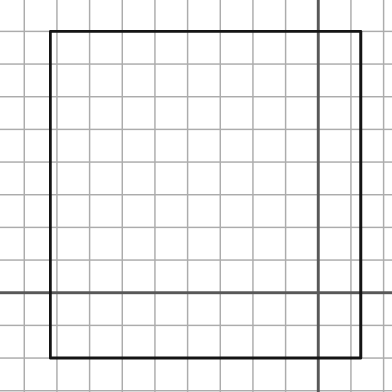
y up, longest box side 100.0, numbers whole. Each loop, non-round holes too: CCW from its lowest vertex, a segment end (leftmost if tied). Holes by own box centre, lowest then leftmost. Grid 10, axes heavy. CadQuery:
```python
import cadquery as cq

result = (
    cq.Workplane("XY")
    .moveTo(-82.0, -20.0)
    .lineTo(13.0, -20.0)
    .lineTo(13.0, 80.0)
    .lineTo(-82.0, 80.0)
    .close()
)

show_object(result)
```